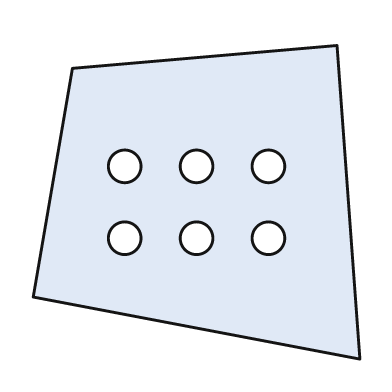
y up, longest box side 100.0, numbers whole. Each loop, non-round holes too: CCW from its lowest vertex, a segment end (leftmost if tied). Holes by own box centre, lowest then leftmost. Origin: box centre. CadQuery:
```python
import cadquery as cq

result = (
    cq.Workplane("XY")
    .moveTo(50.0, -48.0)
    .lineTo(43.0, 48.0)
    .lineTo(-38.0, 41.0)
    .lineTo(-50.0, -29.0)
    .close()
    .moveTo(-22.0, -11.0)
    .circle(5.0)
    .moveTo(0.0, -11.0)
    .circle(5.0)
    .moveTo(22.0, -11.0)
    .circle(5.0)
    .moveTo(-22.0, 11.0)
    .circle(5.0)
    .moveTo(0.0, 11.0)
    .circle(5.0)
    .moveTo(22.0, 11.0)
    .circle(5.0)
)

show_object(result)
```